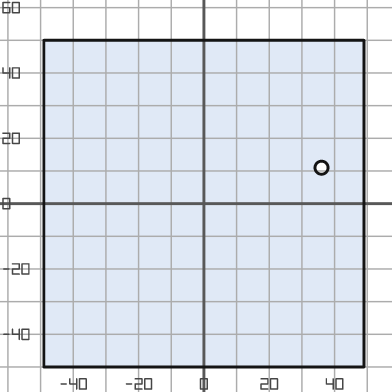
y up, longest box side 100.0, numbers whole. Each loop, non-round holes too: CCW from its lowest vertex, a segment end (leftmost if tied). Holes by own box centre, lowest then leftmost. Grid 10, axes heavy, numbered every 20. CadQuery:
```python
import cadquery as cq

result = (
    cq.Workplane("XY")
    .moveTo(-49.0, -50.0)
    .lineTo(49.0, -50.0)
    .lineTo(49.0, 50.0)
    .lineTo(-49.0, 50.0)
    .close()
    .moveTo(36.0, 11.0)
    .circle(2.0)
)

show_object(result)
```